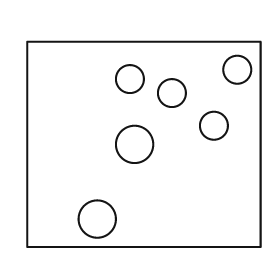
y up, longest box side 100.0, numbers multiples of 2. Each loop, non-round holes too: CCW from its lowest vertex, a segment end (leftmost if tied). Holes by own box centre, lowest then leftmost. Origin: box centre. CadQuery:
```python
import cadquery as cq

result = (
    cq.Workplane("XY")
    .moveTo(-50.0, -44.0)
    .lineTo(50.0, -44.0)
    .lineTo(50.0, 44.0)
    .lineTo(-50.0, 44.0)
    .close()
    .moveTo(-20.0, -32.0)
    .circle(8.0)
    .moveTo(-4.0, 0.0)
    .circle(8.0)
    .moveTo(30.0, 8.0)
    .circle(6.0)
    .moveTo(12.0, 22.0)
    .circle(6.0)
    .moveTo(-6.0, 28.0)
    .circle(6.0)
    .moveTo(40.0, 32.0)
    .circle(6.0)
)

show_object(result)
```